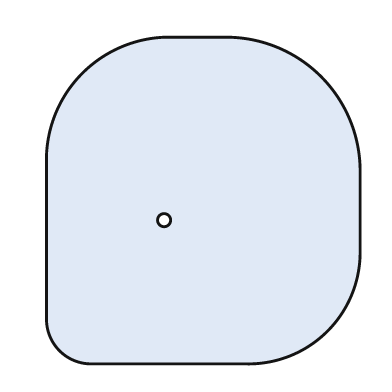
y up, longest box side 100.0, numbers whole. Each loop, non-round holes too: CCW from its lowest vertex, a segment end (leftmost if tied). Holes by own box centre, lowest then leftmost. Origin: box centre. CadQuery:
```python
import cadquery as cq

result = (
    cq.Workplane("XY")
    .moveTo(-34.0, -50.0)
    .lineTo(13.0, -50.0)
    .threePointArc((38.0, -40.0), (48.0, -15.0))
    .lineTo(48.0, 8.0)
    .threePointArc((36.0, 38.0), (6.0, 50.0))
    .lineTo(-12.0, 50.0)
    .threePointArc((-37.0, 39.0), (-48.0, 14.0))
    .lineTo(-48.0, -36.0)
    .threePointArc((-44.0, -46.0), (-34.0, -50.0))
    .close()
    .moveTo(-12.0, -6.0)
    .circle(2.0)
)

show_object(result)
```